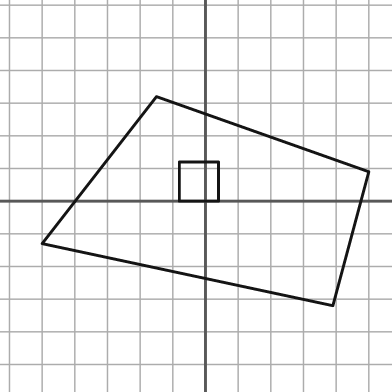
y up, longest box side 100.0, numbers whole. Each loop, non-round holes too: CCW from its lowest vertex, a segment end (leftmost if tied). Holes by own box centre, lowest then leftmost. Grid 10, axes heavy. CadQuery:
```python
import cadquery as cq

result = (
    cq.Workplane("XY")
    .moveTo(39.0, -32.0)
    .lineTo(50.0, 9.0)
    .lineTo(-15.0, 32.0)
    .lineTo(-50.0, -13.0)
    .close()
    .moveTo(-8.0, 0.0)
    .lineTo(4.0, 0.0)
    .lineTo(4.0, 12.0)
    .lineTo(-8.0, 12.0)
    .close()
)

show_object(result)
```